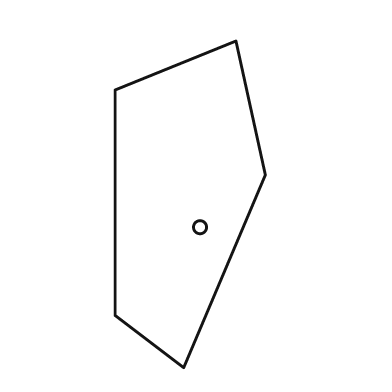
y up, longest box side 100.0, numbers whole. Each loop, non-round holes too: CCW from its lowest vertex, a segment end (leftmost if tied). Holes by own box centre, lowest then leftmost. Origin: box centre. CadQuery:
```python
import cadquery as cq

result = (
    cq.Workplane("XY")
    .moveTo(-2.0, -50.0)
    .lineTo(23.0, 9.0)
    .lineTo(14.0, 50.0)
    .lineTo(-23.0, 35.0)
    .lineTo(-23.0, -34.0)
    .close()
    .moveTo(3.0, -7.0)
    .circle(2.0)
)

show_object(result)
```